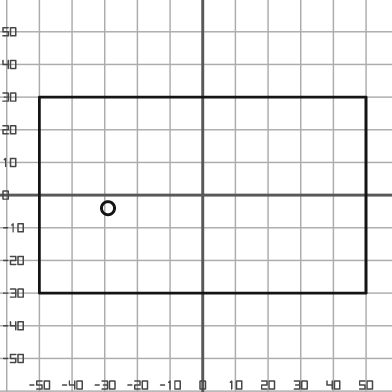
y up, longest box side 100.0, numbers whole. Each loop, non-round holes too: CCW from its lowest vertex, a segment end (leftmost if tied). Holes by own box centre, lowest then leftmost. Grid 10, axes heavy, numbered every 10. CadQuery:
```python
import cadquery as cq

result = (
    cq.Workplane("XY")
    .moveTo(-50.0, -30.0)
    .lineTo(50.0, -30.0)
    .lineTo(50.0, 30.0)
    .lineTo(-50.0, 30.0)
    .close()
    .moveTo(-29.0, -4.0)
    .circle(2.0)
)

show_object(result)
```